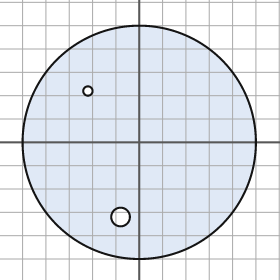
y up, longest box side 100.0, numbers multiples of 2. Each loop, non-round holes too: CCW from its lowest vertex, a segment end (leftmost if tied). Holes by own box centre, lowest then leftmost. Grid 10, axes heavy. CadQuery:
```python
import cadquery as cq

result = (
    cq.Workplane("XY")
    .moveTo(0.0, 0.0)
    .circle(50.0)
    .moveTo(-8.0, -32.0)
    .circle(4.0)
    .moveTo(-22.0, 22.0)
    .circle(2.0)
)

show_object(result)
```